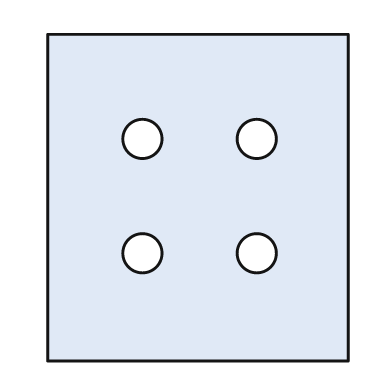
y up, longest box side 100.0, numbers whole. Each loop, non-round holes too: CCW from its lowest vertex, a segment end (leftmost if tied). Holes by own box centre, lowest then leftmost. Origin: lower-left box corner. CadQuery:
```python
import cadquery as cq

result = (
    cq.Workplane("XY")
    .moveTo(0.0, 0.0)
    .lineTo(92.0, 0.0)
    .lineTo(92.0, 100.0)
    .lineTo(0.0, 100.0)
    .close()
    .moveTo(29.0, 33.0)
    .circle(6.0)
    .moveTo(64.0, 33.0)
    .circle(6.0)
    .moveTo(29.0, 68.0)
    .circle(6.0)
    .moveTo(64.0, 68.0)
    .circle(6.0)
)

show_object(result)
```